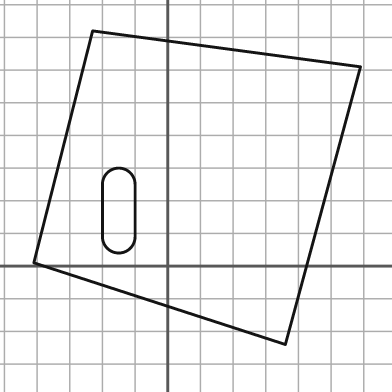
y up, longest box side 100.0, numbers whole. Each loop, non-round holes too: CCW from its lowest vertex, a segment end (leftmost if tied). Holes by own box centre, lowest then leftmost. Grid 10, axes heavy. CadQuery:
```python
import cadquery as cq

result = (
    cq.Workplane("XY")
    .moveTo(36.0, -24.0)
    .lineTo(59.0, 61.0)
    .lineTo(-23.0, 72.0)
    .lineTo(-41.0, 1.0)
    .close()
    .moveTo(-20.0, 9.0)
    .threePointArc((-15.0, 4.0), (-10.0, 9.0))
    .lineTo(-10.0, 25.0)
    .threePointArc((-15.0, 30.0), (-20.0, 25.0))
    .close()
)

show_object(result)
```